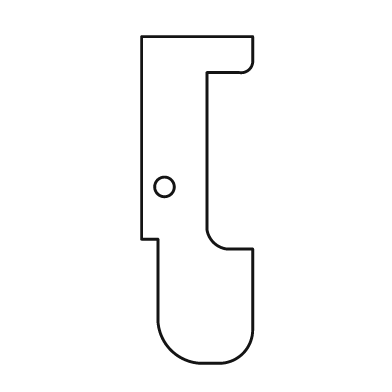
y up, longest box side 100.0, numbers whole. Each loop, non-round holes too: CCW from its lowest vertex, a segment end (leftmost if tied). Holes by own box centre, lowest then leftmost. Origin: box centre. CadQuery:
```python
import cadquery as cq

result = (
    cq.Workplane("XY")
    .moveTo(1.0, -50.0)
    .lineTo(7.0, -50.0)
    .threePointArc((14.0, -47.0), (17.0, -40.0))
    .lineTo(17.0, -15.0)
    .lineTo(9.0, -15.0)
    .threePointArc((5.0, -13.0), (3.0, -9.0))
    .lineTo(3.0, 39.0)
    .lineTo(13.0, 39.0)
    .threePointArc((16.0, 40.0), (17.0, 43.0))
    .lineTo(17.0, 50.0)
    .lineTo(-17.0, 50.0)
    .lineTo(-17.0, -12.0)
    .lineTo(-12.0, -12.0)
    .lineTo(-12.0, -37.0)
    .threePointArc((-8.0, -46.0), (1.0, -50.0))
    .close()
    .moveTo(-10.0, 4.0)
    .circle(3.0)
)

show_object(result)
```